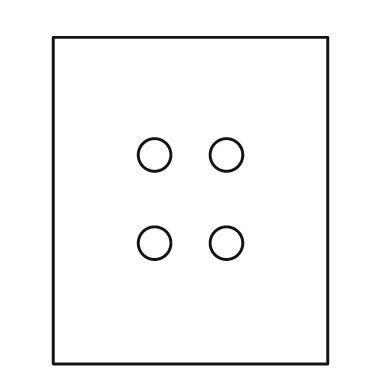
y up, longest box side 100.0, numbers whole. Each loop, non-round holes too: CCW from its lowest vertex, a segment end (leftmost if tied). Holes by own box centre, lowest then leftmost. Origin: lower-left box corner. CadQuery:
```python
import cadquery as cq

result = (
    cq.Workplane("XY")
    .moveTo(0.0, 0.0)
    .lineTo(84.0, 0.0)
    .lineTo(84.0, 100.0)
    .lineTo(0.0, 100.0)
    .close()
    .moveTo(31.0, 37.0)
    .circle(5.0)
    .moveTo(53.0, 37.0)
    .circle(5.0)
    .moveTo(31.0, 64.0)
    .circle(5.0)
    .moveTo(53.0, 64.0)
    .circle(5.0)
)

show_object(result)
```